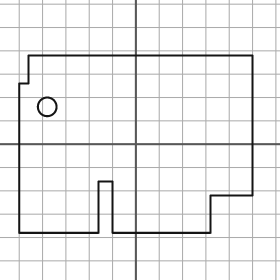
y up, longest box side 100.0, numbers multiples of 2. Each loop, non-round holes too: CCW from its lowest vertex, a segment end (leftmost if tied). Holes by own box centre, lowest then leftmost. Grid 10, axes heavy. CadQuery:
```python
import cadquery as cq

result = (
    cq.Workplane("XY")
    .moveTo(-50.0, -38.0)
    .lineTo(-16.0, -38.0)
    .lineTo(-16.0, -16.0)
    .lineTo(-10.0, -16.0)
    .lineTo(-10.0, -38.0)
    .lineTo(32.0, -38.0)
    .lineTo(32.0, -22.0)
    .lineTo(50.0, -22.0)
    .lineTo(50.0, 38.0)
    .lineTo(-46.0, 38.0)
    .lineTo(-46.0, 26.0)
    .lineTo(-50.0, 26.0)
    .close()
    .moveTo(-38.0, 16.0)
    .circle(4.0)
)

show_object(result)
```